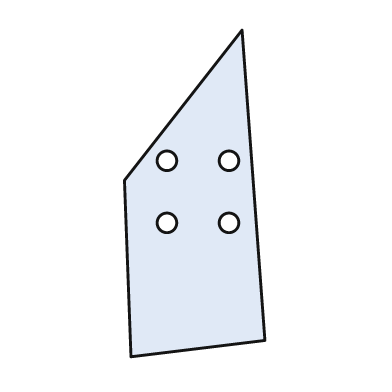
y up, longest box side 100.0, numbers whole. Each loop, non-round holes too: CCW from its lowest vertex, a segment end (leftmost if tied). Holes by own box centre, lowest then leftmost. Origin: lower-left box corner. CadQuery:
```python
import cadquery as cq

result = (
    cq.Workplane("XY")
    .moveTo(2.0, 0.0)
    .lineTo(43.0, 5.0)
    .lineTo(36.0, 100.0)
    .lineTo(0.0, 54.0)
    .close()
    .moveTo(13.0, 41.0)
    .circle(3.0)
    .moveTo(32.0, 41.0)
    .circle(3.0)
    .moveTo(13.0, 60.0)
    .circle(3.0)
    .moveTo(32.0, 60.0)
    .circle(3.0)
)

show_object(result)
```